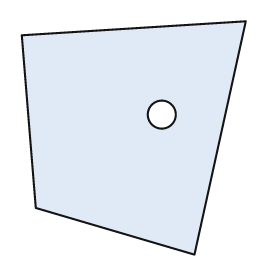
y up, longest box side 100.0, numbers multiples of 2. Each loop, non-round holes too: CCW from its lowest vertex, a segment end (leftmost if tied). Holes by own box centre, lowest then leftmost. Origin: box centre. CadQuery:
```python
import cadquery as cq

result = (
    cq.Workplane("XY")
    .moveTo(26.0, -50.0)
    .lineTo(48.0, 50.0)
    .lineTo(-48.0, 44.0)
    .lineTo(-42.0, -30.0)
    .close()
    .moveTo(12.0, 10.0)
    .circle(6.0)
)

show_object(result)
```